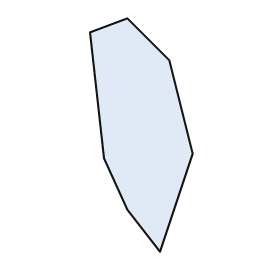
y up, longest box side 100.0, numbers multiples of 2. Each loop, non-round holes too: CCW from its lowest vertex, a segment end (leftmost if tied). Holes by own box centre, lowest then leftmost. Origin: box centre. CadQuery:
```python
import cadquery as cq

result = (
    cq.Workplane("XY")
    .moveTo(8.0, -50.0)
    .lineTo(22.0, -8.0)
    .lineTo(12.0, 32.0)
    .lineTo(-6.0, 50.0)
    .lineTo(-22.0, 44.0)
    .lineTo(-16.0, -10.0)
    .lineTo(-6.0, -32.0)
    .close()
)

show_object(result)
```